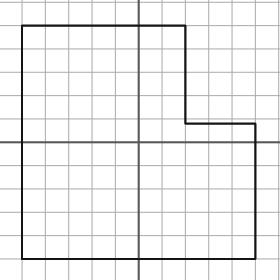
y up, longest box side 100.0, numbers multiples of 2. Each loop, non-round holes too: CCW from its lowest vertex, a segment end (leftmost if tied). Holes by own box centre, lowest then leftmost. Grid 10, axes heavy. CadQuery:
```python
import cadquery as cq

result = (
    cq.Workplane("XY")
    .moveTo(-50.0, -50.0)
    .lineTo(50.0, -50.0)
    .lineTo(50.0, 8.0)
    .lineTo(20.0, 8.0)
    .lineTo(20.0, 50.0)
    .lineTo(-50.0, 50.0)
    .close()
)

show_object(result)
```